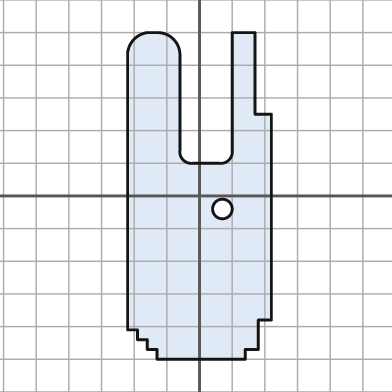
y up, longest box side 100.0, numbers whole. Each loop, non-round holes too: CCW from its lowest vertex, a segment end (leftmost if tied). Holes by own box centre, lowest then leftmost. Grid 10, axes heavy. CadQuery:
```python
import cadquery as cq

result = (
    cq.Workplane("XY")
    .moveTo(-13.0, -50.0)
    .lineTo(14.0, -50.0)
    .lineTo(14.0, -47.0)
    .lineTo(18.0, -47.0)
    .lineTo(18.0, -38.0)
    .lineTo(22.0, -38.0)
    .lineTo(22.0, 25.0)
    .lineTo(17.0, 25.0)
    .lineTo(17.0, 50.0)
    .lineTo(10.0, 50.0)
    .lineTo(10.0, 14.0)
    .threePointArc((9.0, 11.0), (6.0, 10.0))
    .lineTo(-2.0, 10.0)
    .threePointArc((-5.0, 11.0), (-6.0, 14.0))
    .lineTo(-6.0, 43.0)
    .threePointArc((-8.0, 48.0), (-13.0, 50.0))
    .lineTo(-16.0, 50.0)
    .threePointArc((-20.0, 48.0), (-22.0, 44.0))
    .lineTo(-22.0, -41.0)
    .lineTo(-19.0, -41.0)
    .lineTo(-19.0, -44.0)
    .lineTo(-16.0, -44.0)
    .lineTo(-16.0, -47.0)
    .lineTo(-13.0, -47.0)
    .close()
    .moveTo(7.0, -4.0)
    .circle(3.0)
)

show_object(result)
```